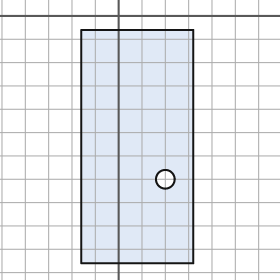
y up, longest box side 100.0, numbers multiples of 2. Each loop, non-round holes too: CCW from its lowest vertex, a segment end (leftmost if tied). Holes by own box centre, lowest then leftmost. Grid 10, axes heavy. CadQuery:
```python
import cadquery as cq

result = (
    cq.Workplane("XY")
    .moveTo(-16.0, -106.0)
    .lineTo(32.0, -106.0)
    .lineTo(32.0, -6.0)
    .lineTo(-16.0, -6.0)
    .close()
    .moveTo(20.0, -70.0)
    .circle(4.0)
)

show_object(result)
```